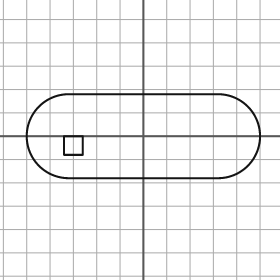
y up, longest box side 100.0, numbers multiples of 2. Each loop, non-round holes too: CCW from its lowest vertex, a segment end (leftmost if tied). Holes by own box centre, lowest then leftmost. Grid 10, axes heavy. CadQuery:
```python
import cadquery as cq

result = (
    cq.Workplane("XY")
    .moveTo(-32.0, -18.0)
    .lineTo(32.0, -18.0)
    .threePointArc((50.0, 0.0), (32.0, 18.0))
    .lineTo(-32.0, 18.0)
    .threePointArc((-50.0, 0.0), (-32.0, -18.0))
    .close()
    .moveTo(-34.0, -8.0)
    .lineTo(-26.0, -8.0)
    .lineTo(-26.0, 0.0)
    .lineTo(-34.0, 0.0)
    .close()
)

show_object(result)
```